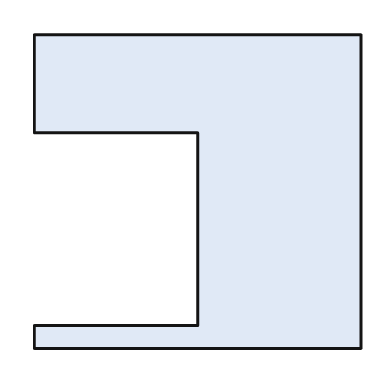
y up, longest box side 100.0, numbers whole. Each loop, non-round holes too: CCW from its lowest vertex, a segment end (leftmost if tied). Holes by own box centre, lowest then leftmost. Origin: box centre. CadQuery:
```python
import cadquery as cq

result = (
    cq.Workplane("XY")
    .moveTo(-50.0, -48.0)
    .lineTo(50.0, -48.0)
    .lineTo(50.0, 48.0)
    .lineTo(-50.0, 48.0)
    .lineTo(-50.0, 18.0)
    .lineTo(0.0, 18.0)
    .lineTo(0.0, -41.0)
    .lineTo(-50.0, -41.0)
    .close()
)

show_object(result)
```